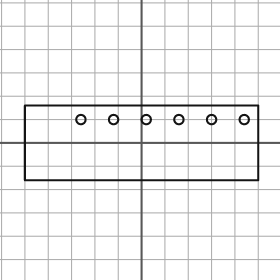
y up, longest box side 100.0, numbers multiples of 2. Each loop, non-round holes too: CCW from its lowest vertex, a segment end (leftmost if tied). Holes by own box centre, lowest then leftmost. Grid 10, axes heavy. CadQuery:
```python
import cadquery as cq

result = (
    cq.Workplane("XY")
    .moveTo(-50.0, -16.0)
    .lineTo(50.0, -16.0)
    .lineTo(50.0, 16.0)
    .lineTo(-50.0, 16.0)
    .close()
    .moveTo(-26.0, 10.0)
    .circle(2.0)
    .moveTo(-12.0, 10.0)
    .circle(2.0)
    .moveTo(2.0, 10.0)
    .circle(2.0)
    .moveTo(16.0, 10.0)
    .circle(2.0)
    .moveTo(30.0, 10.0)
    .circle(2.0)
    .moveTo(44.0, 10.0)
    .circle(2.0)
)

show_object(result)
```